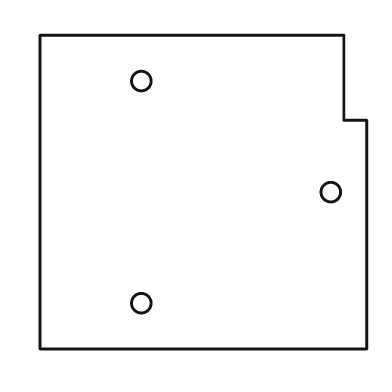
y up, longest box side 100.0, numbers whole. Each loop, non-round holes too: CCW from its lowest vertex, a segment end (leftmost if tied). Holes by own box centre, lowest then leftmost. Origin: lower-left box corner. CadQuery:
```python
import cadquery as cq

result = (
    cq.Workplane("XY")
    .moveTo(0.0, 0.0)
    .lineTo(100.0, 0.0)
    .lineTo(100.0, 70.0)
    .lineTo(93.0, 70.0)
    .lineTo(93.0, 96.0)
    .lineTo(0.0, 96.0)
    .close()
    .moveTo(31.0, 14.0)
    .circle(3.0)
    .moveTo(89.0, 48.0)
    .circle(3.0)
    .moveTo(31.0, 82.0)
    .circle(3.0)
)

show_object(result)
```